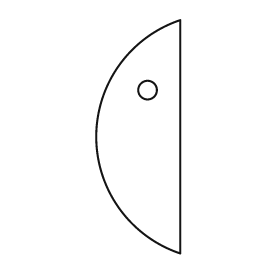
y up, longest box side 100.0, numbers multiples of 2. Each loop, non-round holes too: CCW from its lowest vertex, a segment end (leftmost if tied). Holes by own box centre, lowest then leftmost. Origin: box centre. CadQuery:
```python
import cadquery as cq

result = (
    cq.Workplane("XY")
    .moveTo(18.0, -50.0)
    .lineTo(18.0, 50.0)
    .threePointArc((-18.0, 0.0), (18.0, -50.0))
    .close()
    .moveTo(4.0, 20.0)
    .circle(4.0)
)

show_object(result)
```